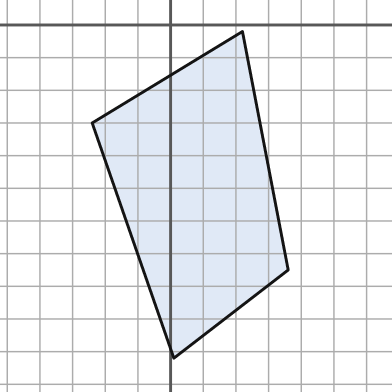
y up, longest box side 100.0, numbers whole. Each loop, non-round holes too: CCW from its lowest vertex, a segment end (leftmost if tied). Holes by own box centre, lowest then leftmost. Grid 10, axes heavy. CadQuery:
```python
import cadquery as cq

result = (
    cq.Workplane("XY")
    .moveTo(1.0, -102.0)
    .lineTo(36.0, -75.0)
    .lineTo(22.0, -2.0)
    .lineTo(-24.0, -30.0)
    .close()
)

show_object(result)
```